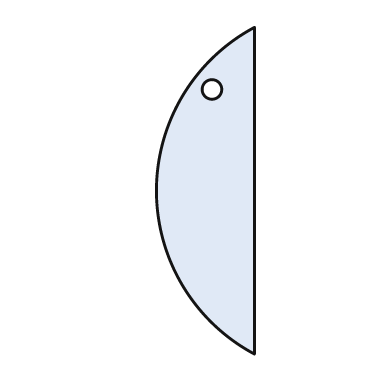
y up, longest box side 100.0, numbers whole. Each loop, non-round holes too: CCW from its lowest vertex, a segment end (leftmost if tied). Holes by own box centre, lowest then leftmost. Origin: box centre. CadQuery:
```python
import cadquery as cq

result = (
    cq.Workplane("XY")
    .moveTo(15.0, -50.0)
    .lineTo(15.0, 50.0)
    .threePointArc((-15.0, 0.0), (15.0, -50.0))
    .close()
    .moveTo(2.0, 31.0)
    .circle(3.0)
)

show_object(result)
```